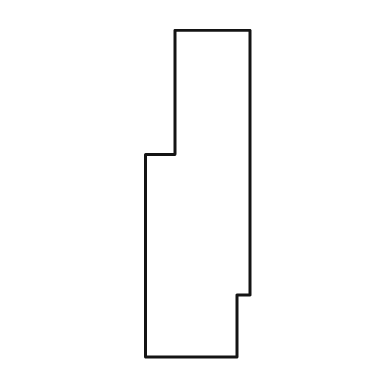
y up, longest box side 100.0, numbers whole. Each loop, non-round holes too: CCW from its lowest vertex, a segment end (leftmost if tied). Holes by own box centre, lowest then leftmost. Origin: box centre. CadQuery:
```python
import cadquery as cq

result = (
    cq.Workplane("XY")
    .moveTo(-16.0, -50.0)
    .lineTo(12.0, -50.0)
    .lineTo(12.0, -31.0)
    .lineTo(16.0, -31.0)
    .lineTo(16.0, 50.0)
    .lineTo(-7.0, 50.0)
    .lineTo(-7.0, 12.0)
    .lineTo(-16.0, 12.0)
    .close()
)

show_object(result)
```